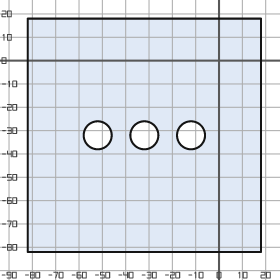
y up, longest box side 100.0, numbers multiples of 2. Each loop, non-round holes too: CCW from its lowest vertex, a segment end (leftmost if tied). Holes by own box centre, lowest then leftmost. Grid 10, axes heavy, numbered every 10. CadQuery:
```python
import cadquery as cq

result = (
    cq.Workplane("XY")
    .moveTo(-82.0, -82.0)
    .lineTo(18.0, -82.0)
    .lineTo(18.0, 18.0)
    .lineTo(-82.0, 18.0)
    .close()
    .moveTo(-52.0, -32.0)
    .circle(6.0)
    .moveTo(-32.0, -32.0)
    .circle(6.0)
    .moveTo(-12.0, -32.0)
    .circle(6.0)
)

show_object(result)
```